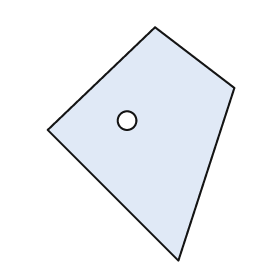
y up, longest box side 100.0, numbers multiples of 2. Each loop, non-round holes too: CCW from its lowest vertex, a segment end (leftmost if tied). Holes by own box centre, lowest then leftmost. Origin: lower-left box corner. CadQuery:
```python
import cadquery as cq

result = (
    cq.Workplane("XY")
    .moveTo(56.0, 0.0)
    .lineTo(80.0, 74.0)
    .lineTo(46.0, 100.0)
    .lineTo(0.0, 56.0)
    .close()
    .moveTo(34.0, 60.0)
    .circle(4.0)
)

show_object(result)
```